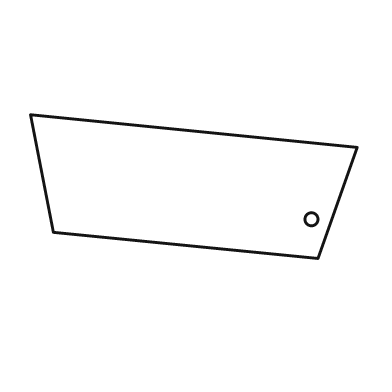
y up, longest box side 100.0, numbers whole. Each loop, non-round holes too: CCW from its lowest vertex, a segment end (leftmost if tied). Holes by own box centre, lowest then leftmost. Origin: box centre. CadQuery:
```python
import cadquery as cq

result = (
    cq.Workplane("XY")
    .moveTo(38.0, -22.0)
    .lineTo(50.0, 12.0)
    .lineTo(-50.0, 22.0)
    .lineTo(-43.0, -14.0)
    .close()
    .moveTo(36.0, -10.0)
    .circle(2.0)
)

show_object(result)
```